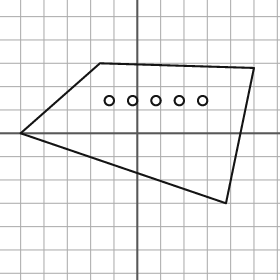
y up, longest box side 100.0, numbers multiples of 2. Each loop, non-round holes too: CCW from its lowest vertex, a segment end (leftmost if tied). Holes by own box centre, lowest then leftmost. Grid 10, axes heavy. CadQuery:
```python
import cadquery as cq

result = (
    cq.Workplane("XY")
    .moveTo(38.0, -30.0)
    .lineTo(50.0, 28.0)
    .lineTo(-16.0, 30.0)
    .lineTo(-50.0, 0.0)
    .close()
    .moveTo(-12.0, 14.0)
    .circle(2.0)
    .moveTo(-2.0, 14.0)
    .circle(2.0)
    .moveTo(8.0, 14.0)
    .circle(2.0)
    .moveTo(18.0, 14.0)
    .circle(2.0)
    .moveTo(28.0, 14.0)
    .circle(2.0)
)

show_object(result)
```